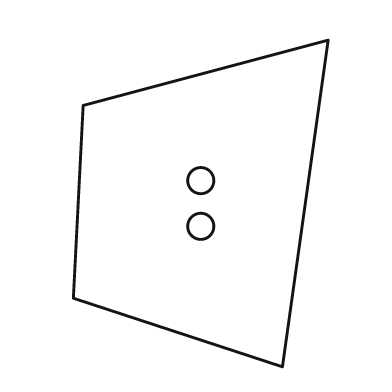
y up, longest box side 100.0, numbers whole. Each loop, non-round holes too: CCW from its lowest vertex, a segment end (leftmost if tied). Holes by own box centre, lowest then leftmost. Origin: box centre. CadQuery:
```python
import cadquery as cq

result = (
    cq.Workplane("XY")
    .moveTo(25.0, -50.0)
    .lineTo(39.0, 50.0)
    .lineTo(-36.0, 30.0)
    .lineTo(-39.0, -29.0)
    .close()
    .moveTo(0.0, -7.0)
    .circle(4.0)
    .moveTo(0.0, 7.0)
    .circle(4.0)
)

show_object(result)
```